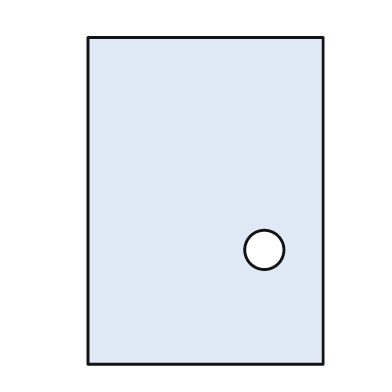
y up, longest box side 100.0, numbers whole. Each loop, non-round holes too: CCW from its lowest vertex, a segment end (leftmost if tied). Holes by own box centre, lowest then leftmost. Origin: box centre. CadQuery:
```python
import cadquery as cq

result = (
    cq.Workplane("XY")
    .moveTo(-36.0, -50.0)
    .lineTo(36.0, -50.0)
    .lineTo(36.0, 50.0)
    .lineTo(-36.0, 50.0)
    .close()
    .moveTo(18.0, -15.0)
    .circle(6.0)
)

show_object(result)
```